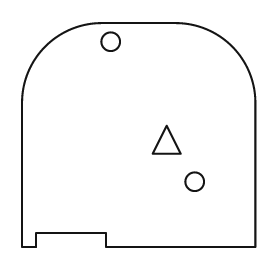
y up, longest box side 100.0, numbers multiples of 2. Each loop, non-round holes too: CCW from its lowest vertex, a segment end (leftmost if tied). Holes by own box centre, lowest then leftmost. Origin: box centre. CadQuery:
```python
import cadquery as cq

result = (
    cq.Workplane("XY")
    .moveTo(-50.0, -48.0)
    .lineTo(-44.0, -48.0)
    .lineTo(-44.0, -42.0)
    .lineTo(-14.0, -42.0)
    .lineTo(-14.0, -48.0)
    .lineTo(50.0, -48.0)
    .lineTo(50.0, 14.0)
    .threePointArc((40.0, 38.0), (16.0, 48.0))
    .lineTo(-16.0, 48.0)
    .threePointArc((-40.0, 38.0), (-50.0, 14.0))
    .close()
    .moveTo(24.0, -20.0)
    .circle(4.0)
    .moveTo(6.0, -8.0)
    .lineTo(18.0, -8.0)
    .lineTo(12.0, 4.0)
    .close()
    .moveTo(-12.0, 40.0)
    .circle(4.0)
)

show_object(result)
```